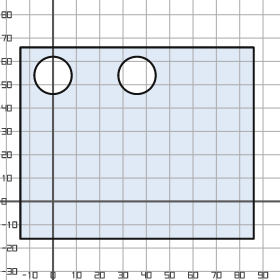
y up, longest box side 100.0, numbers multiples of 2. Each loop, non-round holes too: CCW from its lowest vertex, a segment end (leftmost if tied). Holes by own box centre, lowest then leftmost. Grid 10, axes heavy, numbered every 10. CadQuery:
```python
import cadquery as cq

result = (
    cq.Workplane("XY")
    .moveTo(-14.0, -16.0)
    .lineTo(86.0, -16.0)
    .lineTo(86.0, 66.0)
    .lineTo(-14.0, 66.0)
    .close()
    .moveTo(0.0, 54.0)
    .circle(8.0)
    .moveTo(36.0, 54.0)
    .circle(8.0)
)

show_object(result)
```